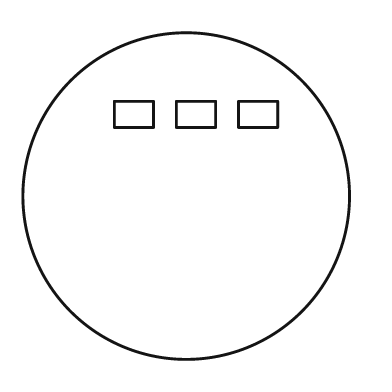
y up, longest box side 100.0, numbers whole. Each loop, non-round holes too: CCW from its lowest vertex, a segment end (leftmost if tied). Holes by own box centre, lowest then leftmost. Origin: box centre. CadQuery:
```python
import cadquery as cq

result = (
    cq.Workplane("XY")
    .moveTo(0.0, 0.0)
    .circle(50.0)
    .moveTo(-22.0, 21.0)
    .lineTo(-10.0, 21.0)
    .lineTo(-10.0, 29.0)
    .lineTo(-22.0, 29.0)
    .close()
    .moveTo(-3.0, 21.0)
    .lineTo(9.0, 21.0)
    .lineTo(9.0, 29.0)
    .lineTo(-3.0, 29.0)
    .close()
    .moveTo(16.0, 21.0)
    .lineTo(28.0, 21.0)
    .lineTo(28.0, 29.0)
    .lineTo(16.0, 29.0)
    .close()
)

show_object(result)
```